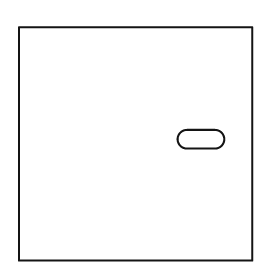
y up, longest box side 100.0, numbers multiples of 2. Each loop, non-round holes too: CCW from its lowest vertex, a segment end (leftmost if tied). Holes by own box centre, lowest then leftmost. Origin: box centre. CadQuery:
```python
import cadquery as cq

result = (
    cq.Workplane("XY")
    .moveTo(-50.0, -50.0)
    .lineTo(50.0, -50.0)
    .lineTo(50.0, 50.0)
    .lineTo(-50.0, 50.0)
    .close()
    .moveTo(22.0, -2.0)
    .lineTo(34.0, -2.0)
    .threePointArc((38.0, 2.0), (34.0, 6.0))
    .lineTo(22.0, 6.0)
    .threePointArc((18.0, 2.0), (22.0, -2.0))
    .close()
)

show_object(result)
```